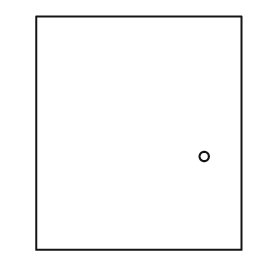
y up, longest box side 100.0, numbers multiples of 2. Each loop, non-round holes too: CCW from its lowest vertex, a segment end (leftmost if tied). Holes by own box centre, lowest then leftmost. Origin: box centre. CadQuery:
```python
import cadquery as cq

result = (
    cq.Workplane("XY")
    .moveTo(-44.0, -50.0)
    .lineTo(44.0, -50.0)
    .lineTo(44.0, 50.0)
    .lineTo(-44.0, 50.0)
    .close()
    .moveTo(28.0, -10.0)
    .circle(2.0)
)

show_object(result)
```